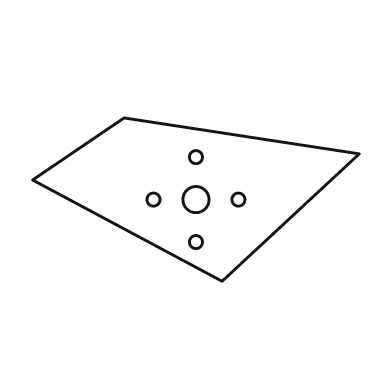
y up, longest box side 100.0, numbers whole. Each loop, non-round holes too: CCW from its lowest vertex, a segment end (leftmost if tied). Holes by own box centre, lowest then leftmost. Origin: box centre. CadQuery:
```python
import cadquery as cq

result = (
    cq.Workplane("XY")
    .moveTo(8.0, -25.0)
    .lineTo(50.0, 14.0)
    .lineTo(-22.0, 25.0)
    .lineTo(-50.0, 6.0)
    .close()
    .moveTo(0.0, -13.0)
    .circle(2.0)
    .moveTo(-13.0, 0.0)
    .circle(2.0)
    .moveTo(0.0, 0.0)
    .circle(4.0)
    .moveTo(13.0, 0.0)
    .circle(2.0)
    .moveTo(0.0, 13.0)
    .circle(2.0)
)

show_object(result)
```